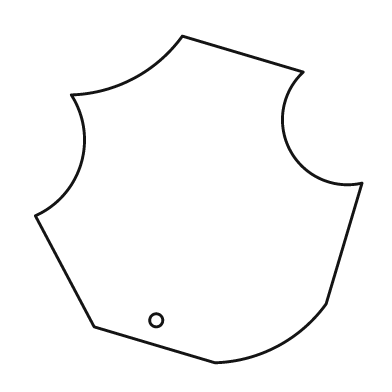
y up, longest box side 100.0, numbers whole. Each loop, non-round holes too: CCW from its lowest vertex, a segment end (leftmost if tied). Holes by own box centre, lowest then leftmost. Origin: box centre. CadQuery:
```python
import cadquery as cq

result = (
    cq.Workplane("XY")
    .moveTo(5.0, -50.0)
    .threePointArc((24.0, -45.0), (39.0, -32.0))
    .lineTo(50.0, 5.0)
    .threePointArc((28.0, 15.0), (32.0, 39.0))
    .lineTo(-5.0, 50.0)
    .threePointArc((-20.0, 37.0), (-39.0, 32.0))
    .threePointArc((-36.0, 11.0), (-50.0, -5.0))
    .lineTo(-32.0, -39.0)
    .close()
    .moveTo(-13.0, -37.0)
    .circle(2.0)
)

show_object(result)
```